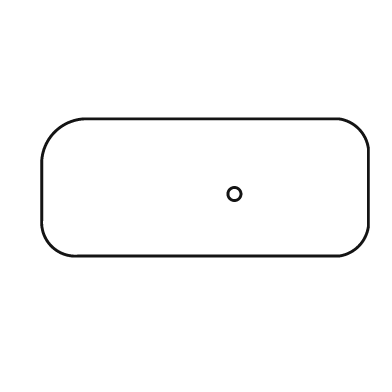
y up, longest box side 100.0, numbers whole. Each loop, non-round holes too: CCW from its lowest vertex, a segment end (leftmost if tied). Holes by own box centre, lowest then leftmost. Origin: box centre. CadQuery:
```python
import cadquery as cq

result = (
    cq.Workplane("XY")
    .moveTo(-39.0, -21.0)
    .lineTo(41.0, -21.0)
    .threePointArc((47.0, -18.0), (50.0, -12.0))
    .lineTo(50.0, 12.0)
    .threePointArc((47.0, 18.0), (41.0, 21.0))
    .lineTo(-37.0, 21.0)
    .threePointArc((-46.0, 17.0), (-50.0, 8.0))
    .lineTo(-50.0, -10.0)
    .threePointArc((-47.0, -18.0), (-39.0, -21.0))
    .close()
    .moveTo(9.0, -2.0)
    .circle(2.0)
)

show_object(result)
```